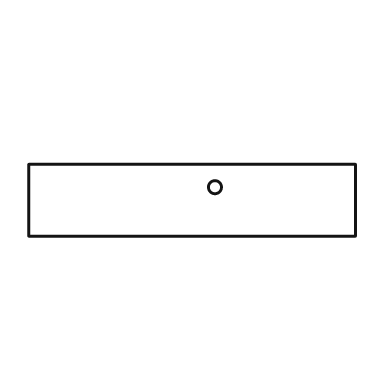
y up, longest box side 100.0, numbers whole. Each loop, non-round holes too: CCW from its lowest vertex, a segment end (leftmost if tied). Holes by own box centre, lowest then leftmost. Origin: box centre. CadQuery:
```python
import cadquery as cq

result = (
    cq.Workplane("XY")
    .moveTo(-50.0, -11.0)
    .lineTo(50.0, -11.0)
    .lineTo(50.0, 11.0)
    .lineTo(-50.0, 11.0)
    .close()
    .moveTo(7.0, 4.0)
    .circle(2.0)
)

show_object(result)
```